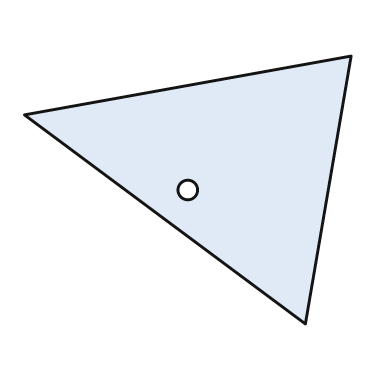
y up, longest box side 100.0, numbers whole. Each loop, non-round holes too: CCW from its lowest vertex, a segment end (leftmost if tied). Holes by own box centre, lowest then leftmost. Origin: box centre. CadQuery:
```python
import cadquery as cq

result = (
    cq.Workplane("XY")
    .moveTo(36.0, -41.0)
    .lineTo(50.0, 41.0)
    .lineTo(-50.0, 23.0)
    .close()
    .moveTo(0.0, 0.0)
    .circle(3.0)
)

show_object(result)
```